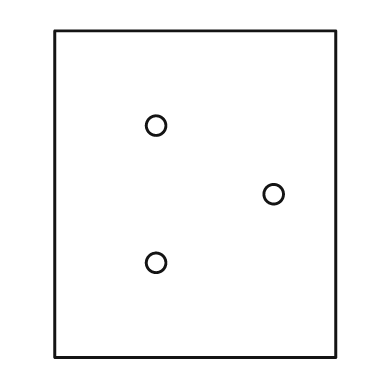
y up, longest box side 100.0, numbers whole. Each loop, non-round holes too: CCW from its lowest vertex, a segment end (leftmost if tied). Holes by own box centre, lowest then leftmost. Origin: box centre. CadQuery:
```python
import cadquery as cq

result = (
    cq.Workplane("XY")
    .moveTo(-43.0, -50.0)
    .lineTo(43.0, -50.0)
    .lineTo(43.0, 50.0)
    .lineTo(-43.0, 50.0)
    .close()
    .moveTo(-12.0, -21.0)
    .circle(3.0)
    .moveTo(24.0, 0.0)
    .circle(3.0)
    .moveTo(-12.0, 21.0)
    .circle(3.0)
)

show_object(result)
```